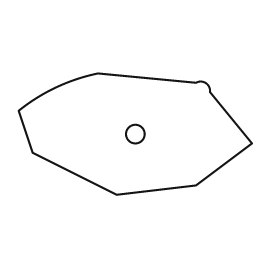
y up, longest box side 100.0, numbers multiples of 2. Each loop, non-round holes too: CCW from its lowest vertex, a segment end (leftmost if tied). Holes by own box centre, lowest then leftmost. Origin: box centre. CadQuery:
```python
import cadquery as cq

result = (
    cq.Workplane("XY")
    .moveTo(-8.0, -26.0)
    .lineTo(26.0, -22.0)
    .lineTo(50.0, -4.0)
    .lineTo(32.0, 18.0)
    .threePointArc((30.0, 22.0), (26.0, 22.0))
    .lineTo(-16.0, 26.0)
    .threePointArc((-34.0, 20.0), (-50.0, 10.0))
    .lineTo(-44.0, -8.0)
    .close()
    .moveTo(0.0, 0.0)
    .circle(4.0)
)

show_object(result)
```